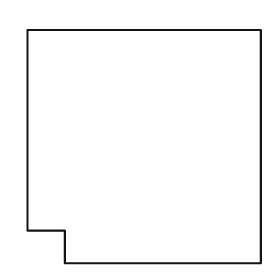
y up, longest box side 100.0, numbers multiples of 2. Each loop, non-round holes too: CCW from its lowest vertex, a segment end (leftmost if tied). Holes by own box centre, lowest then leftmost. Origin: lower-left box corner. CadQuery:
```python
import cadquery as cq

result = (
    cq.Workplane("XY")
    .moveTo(16.0, 0.0)
    .lineTo(100.0, 0.0)
    .lineTo(100.0, 100.0)
    .lineTo(0.0, 100.0)
    .lineTo(0.0, 14.0)
    .lineTo(16.0, 14.0)
    .close()
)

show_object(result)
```